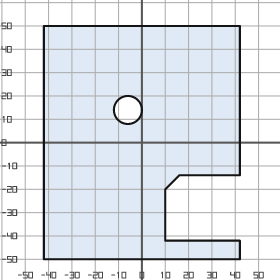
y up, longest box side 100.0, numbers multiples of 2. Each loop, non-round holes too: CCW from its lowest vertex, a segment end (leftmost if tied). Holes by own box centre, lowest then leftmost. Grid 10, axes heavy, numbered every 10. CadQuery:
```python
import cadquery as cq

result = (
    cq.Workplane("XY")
    .moveTo(-42.0, -50.0)
    .lineTo(42.0, -50.0)
    .lineTo(42.0, -42.0)
    .lineTo(10.0, -42.0)
    .lineTo(10.0, -20.0)
    .lineTo(16.0, -14.0)
    .lineTo(42.0, -14.0)
    .lineTo(42.0, 50.0)
    .lineTo(-42.0, 50.0)
    .close()
    .moveTo(-6.0, 14.0)
    .circle(6.0)
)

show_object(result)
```